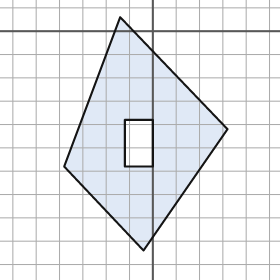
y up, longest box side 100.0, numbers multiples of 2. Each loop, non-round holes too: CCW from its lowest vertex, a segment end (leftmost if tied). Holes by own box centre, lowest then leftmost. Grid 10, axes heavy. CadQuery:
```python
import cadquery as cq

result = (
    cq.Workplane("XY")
    .moveTo(-4.0, -94.0)
    .lineTo(32.0, -42.0)
    .lineTo(-14.0, 6.0)
    .lineTo(-38.0, -58.0)
    .close()
    .moveTo(-12.0, -58.0)
    .lineTo(0.0, -58.0)
    .lineTo(0.0, -38.0)
    .lineTo(-12.0, -38.0)
    .close()
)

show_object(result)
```